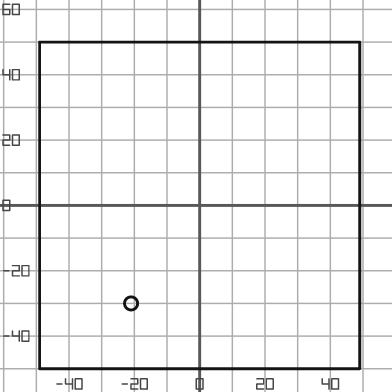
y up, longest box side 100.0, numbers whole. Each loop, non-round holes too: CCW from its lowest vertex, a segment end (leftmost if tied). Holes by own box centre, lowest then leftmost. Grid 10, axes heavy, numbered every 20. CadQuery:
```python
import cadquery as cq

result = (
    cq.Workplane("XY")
    .moveTo(-49.0, -50.0)
    .lineTo(49.0, -50.0)
    .lineTo(49.0, 50.0)
    .lineTo(-49.0, 50.0)
    .close()
    .moveTo(-21.0, -30.0)
    .circle(2.0)
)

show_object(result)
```